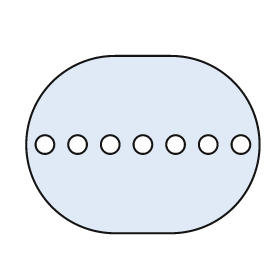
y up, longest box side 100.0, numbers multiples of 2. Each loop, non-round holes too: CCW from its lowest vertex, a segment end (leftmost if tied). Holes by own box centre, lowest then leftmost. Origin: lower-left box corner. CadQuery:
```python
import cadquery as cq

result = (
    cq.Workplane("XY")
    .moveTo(38.0, 0.0)
    .lineTo(62.0, 0.0)
    .threePointArc((100.0, 38.0), (62.0, 76.0))
    .lineTo(38.0, 76.0)
    .threePointArc((0.0, 38.0), (38.0, 0.0))
    .close()
    .moveTo(8.0, 38.0)
    .circle(4.0)
    .moveTo(22.0, 38.0)
    .circle(4.0)
    .moveTo(36.0, 38.0)
    .circle(4.0)
    .moveTo(50.0, 38.0)
    .circle(4.0)
    .moveTo(64.0, 38.0)
    .circle(4.0)
    .moveTo(78.0, 38.0)
    .circle(4.0)
    .moveTo(92.0, 38.0)
    .circle(4.0)
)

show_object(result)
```